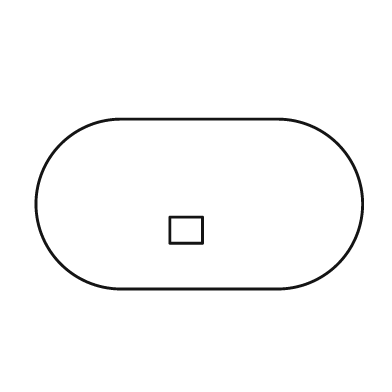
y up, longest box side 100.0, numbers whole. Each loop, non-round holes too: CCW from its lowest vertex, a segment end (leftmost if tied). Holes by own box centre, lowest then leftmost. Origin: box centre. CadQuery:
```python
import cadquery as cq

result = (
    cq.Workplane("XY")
    .moveTo(-24.0, -26.0)
    .lineTo(24.0, -26.0)
    .threePointArc((50.0, 0.0), (24.0, 26.0))
    .lineTo(-24.0, 26.0)
    .threePointArc((-50.0, 0.0), (-24.0, -26.0))
    .close()
    .moveTo(-9.0, -12.0)
    .lineTo(1.0, -12.0)
    .lineTo(1.0, -4.0)
    .lineTo(-9.0, -4.0)
    .close()
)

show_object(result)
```